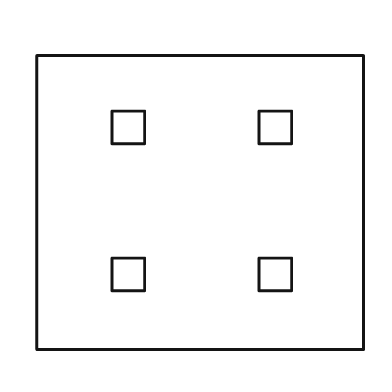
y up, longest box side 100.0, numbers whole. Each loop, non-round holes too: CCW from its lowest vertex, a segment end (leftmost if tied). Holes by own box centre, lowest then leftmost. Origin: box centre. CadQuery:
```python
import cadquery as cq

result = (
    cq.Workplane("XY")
    .moveTo(-50.0, -45.0)
    .lineTo(50.0, -45.0)
    .lineTo(50.0, 45.0)
    .lineTo(-50.0, 45.0)
    .close()
    .moveTo(-27.0, -27.0)
    .lineTo(-17.0, -27.0)
    .lineTo(-17.0, -17.0)
    .lineTo(-27.0, -17.0)
    .close()
    .moveTo(18.0, -27.0)
    .lineTo(28.0, -27.0)
    .lineTo(28.0, -17.0)
    .lineTo(18.0, -17.0)
    .close()
    .moveTo(-27.0, 18.0)
    .lineTo(-17.0, 18.0)
    .lineTo(-17.0, 28.0)
    .lineTo(-27.0, 28.0)
    .close()
    .moveTo(18.0, 18.0)
    .lineTo(28.0, 18.0)
    .lineTo(28.0, 28.0)
    .lineTo(18.0, 28.0)
    .close()
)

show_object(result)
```